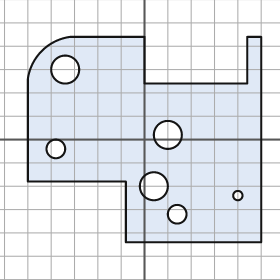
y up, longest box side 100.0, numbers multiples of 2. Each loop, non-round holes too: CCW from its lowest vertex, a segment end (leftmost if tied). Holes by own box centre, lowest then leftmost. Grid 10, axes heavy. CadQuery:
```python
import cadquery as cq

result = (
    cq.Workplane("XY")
    .moveTo(-8.0, -44.0)
    .lineTo(50.0, -44.0)
    .lineTo(50.0, 44.0)
    .lineTo(44.0, 44.0)
    .lineTo(44.0, 24.0)
    .lineTo(0.0, 24.0)
    .lineTo(0.0, 44.0)
    .lineTo(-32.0, 44.0)
    .threePointArc((-44.0, 38.0), (-50.0, 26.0))
    .lineTo(-50.0, -18.0)
    .lineTo(-8.0, -18.0)
    .close()
    .moveTo(14.0, -32.0)
    .circle(4.0)
    .moveTo(40.0, -24.0)
    .circle(2.0)
    .moveTo(4.0, -20.0)
    .circle(6.0)
    .moveTo(-38.0, -4.0)
    .circle(4.0)
    .moveTo(10.0, 2.0)
    .circle(6.0)
    .moveTo(-34.0, 30.0)
    .circle(6.0)
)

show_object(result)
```